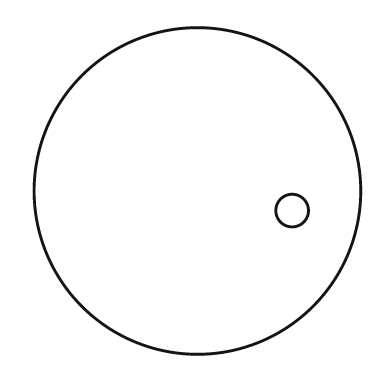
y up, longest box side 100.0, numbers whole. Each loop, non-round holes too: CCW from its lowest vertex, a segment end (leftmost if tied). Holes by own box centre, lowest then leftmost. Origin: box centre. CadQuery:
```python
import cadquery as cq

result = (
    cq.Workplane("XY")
    .moveTo(0.0, 0.0)
    .circle(50.0)
    .moveTo(29.0, -6.0)
    .circle(5.0)
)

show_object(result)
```